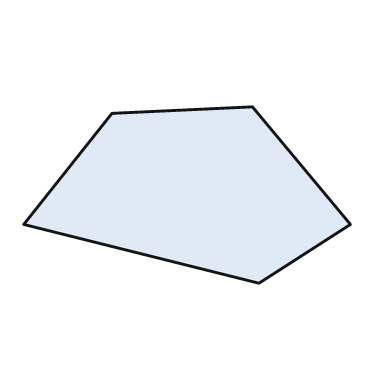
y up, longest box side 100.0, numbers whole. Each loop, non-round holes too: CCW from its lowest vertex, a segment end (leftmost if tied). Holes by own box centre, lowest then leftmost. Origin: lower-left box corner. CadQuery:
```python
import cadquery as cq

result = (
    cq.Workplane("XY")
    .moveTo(72.0, 0.0)
    .lineTo(100.0, 18.0)
    .lineTo(70.0, 54.0)
    .lineTo(27.0, 52.0)
    .lineTo(0.0, 18.0)
    .close()
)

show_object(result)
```